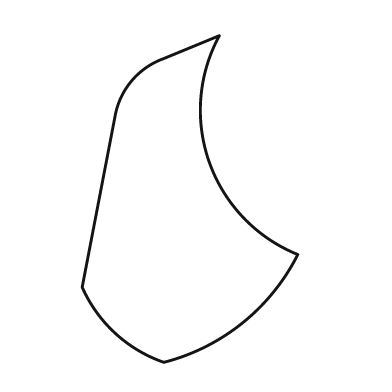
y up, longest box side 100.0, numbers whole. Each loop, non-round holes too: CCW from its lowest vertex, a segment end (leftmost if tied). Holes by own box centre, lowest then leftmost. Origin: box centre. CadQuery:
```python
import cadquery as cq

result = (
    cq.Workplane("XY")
    .moveTo(-8.0, -50.0)
    .threePointArc((16.0, -38.0), (33.0, -17.0))
    .threePointArc((6.0, 11.0), (9.0, 50.0))
    .lineTo(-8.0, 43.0)
    .threePointArc((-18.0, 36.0), (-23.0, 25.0))
    .lineTo(-33.0, -27.0)
    .threePointArc((-23.0, -41.0), (-8.0, -50.0))
    .close()
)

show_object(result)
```